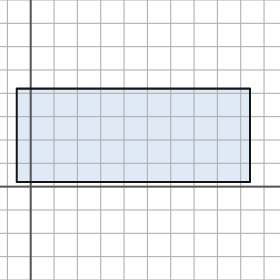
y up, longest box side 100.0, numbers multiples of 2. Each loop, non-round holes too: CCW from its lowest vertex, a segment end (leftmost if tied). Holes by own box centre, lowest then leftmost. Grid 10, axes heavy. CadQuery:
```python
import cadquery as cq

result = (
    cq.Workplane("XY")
    .moveTo(-6.0, 2.0)
    .lineTo(94.0, 2.0)
    .lineTo(94.0, 42.0)
    .lineTo(-6.0, 42.0)
    .close()
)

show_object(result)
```